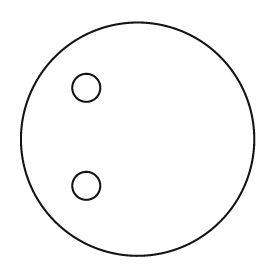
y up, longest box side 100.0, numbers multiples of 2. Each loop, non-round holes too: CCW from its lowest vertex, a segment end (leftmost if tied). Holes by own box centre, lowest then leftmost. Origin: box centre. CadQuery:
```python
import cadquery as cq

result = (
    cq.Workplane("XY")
    .moveTo(0.0, 0.0)
    .circle(50.0)
    .moveTo(-22.0, -20.0)
    .circle(6.0)
    .moveTo(-22.0, 22.0)
    .circle(6.0)
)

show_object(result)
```